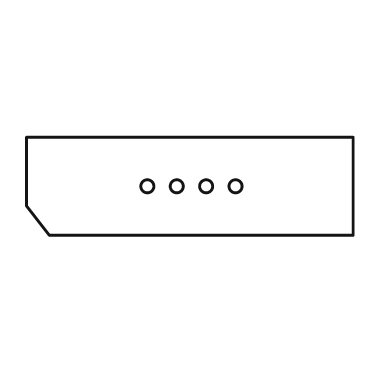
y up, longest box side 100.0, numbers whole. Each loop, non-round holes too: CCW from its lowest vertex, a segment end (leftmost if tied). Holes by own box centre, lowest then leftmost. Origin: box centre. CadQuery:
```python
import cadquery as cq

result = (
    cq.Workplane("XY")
    .moveTo(-43.0, -15.0)
    .lineTo(50.0, -15.0)
    .lineTo(50.0, 15.0)
    .lineTo(-50.0, 15.0)
    .lineTo(-50.0, -6.0)
    .close()
    .moveTo(-13.0, 0.0)
    .circle(2.0)
    .moveTo(-4.0, 0.0)
    .circle(2.0)
    .moveTo(5.0, 0.0)
    .circle(2.0)
    .moveTo(14.0, 0.0)
    .circle(2.0)
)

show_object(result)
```